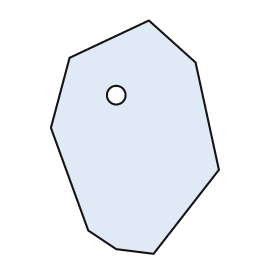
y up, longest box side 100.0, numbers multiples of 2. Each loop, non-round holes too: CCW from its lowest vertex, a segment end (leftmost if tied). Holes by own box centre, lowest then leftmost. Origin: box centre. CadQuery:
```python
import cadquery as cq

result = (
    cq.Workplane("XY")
    .moveTo(8.0, -50.0)
    .lineTo(36.0, -14.0)
    .lineTo(26.0, 32.0)
    .lineTo(6.0, 50.0)
    .lineTo(-28.0, 34.0)
    .lineTo(-36.0, 4.0)
    .lineTo(-20.0, -40.0)
    .lineTo(-8.0, -48.0)
    .close()
    .moveTo(-8.0, 18.0)
    .circle(4.0)
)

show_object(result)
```